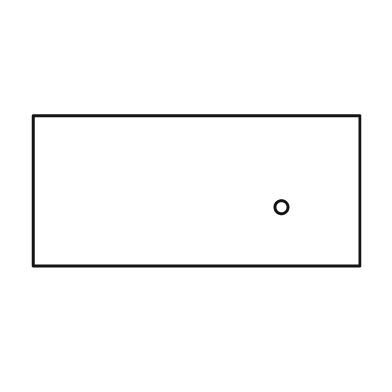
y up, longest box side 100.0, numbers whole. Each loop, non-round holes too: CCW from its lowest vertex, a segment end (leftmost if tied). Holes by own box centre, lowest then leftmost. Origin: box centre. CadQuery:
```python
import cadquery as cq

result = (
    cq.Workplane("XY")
    .moveTo(-50.0, -23.0)
    .lineTo(50.0, -23.0)
    .lineTo(50.0, 23.0)
    .lineTo(-50.0, 23.0)
    .close()
    .moveTo(26.0, -5.0)
    .circle(2.0)
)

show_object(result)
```